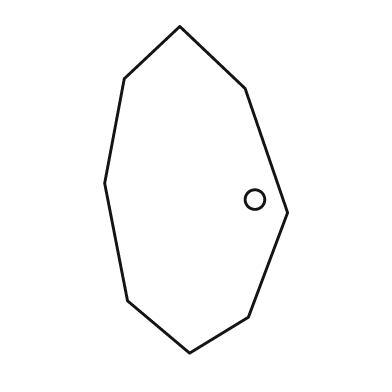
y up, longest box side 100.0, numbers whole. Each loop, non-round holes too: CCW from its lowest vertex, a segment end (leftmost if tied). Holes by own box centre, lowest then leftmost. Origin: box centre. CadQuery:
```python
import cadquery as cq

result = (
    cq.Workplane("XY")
    .moveTo(-2.0, -50.0)
    .lineTo(16.0, -39.0)
    .lineTo(28.0, -7.0)
    .lineTo(15.0, 31.0)
    .lineTo(-5.0, 50.0)
    .lineTo(-22.0, 34.0)
    .lineTo(-28.0, 2.0)
    .lineTo(-21.0, -34.0)
    .close()
    .moveTo(18.0, -3.0)
    .circle(3.0)
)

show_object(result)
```